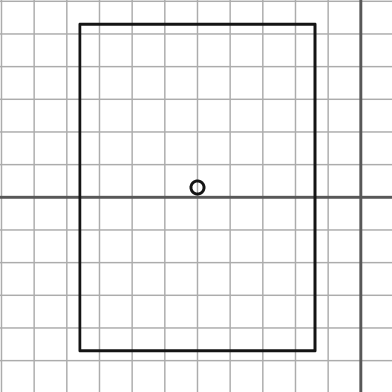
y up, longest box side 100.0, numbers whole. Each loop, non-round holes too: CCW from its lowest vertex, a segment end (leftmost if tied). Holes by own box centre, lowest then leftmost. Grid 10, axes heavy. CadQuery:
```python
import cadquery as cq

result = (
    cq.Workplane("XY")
    .moveTo(-86.0, -47.0)
    .lineTo(-14.0, -47.0)
    .lineTo(-14.0, 53.0)
    .lineTo(-86.0, 53.0)
    .close()
    .moveTo(-50.0, 3.0)
    .circle(2.0)
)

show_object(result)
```